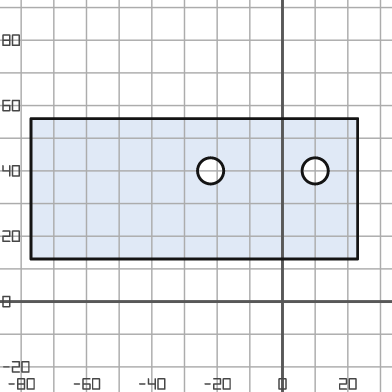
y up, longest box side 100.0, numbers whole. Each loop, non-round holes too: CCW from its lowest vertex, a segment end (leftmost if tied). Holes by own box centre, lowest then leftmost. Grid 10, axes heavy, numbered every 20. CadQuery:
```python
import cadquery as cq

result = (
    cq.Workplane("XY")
    .moveTo(-77.0, 13.0)
    .lineTo(23.0, 13.0)
    .lineTo(23.0, 56.0)
    .lineTo(-77.0, 56.0)
    .close()
    .moveTo(-22.0, 40.0)
    .circle(4.0)
    .moveTo(10.0, 40.0)
    .circle(4.0)
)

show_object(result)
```